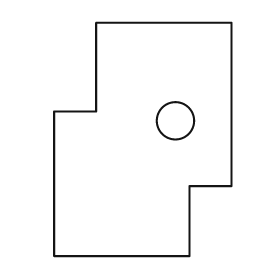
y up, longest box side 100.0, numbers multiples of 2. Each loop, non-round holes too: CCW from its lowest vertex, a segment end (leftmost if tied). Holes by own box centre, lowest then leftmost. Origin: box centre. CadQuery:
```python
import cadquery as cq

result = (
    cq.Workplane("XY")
    .moveTo(-38.0, -50.0)
    .lineTo(20.0, -50.0)
    .lineTo(20.0, -20.0)
    .lineTo(38.0, -20.0)
    .lineTo(38.0, 50.0)
    .lineTo(-20.0, 50.0)
    .lineTo(-20.0, 12.0)
    .lineTo(-38.0, 12.0)
    .close()
    .moveTo(14.0, 8.0)
    .circle(8.0)
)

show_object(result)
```